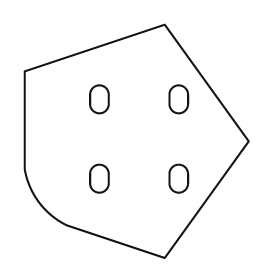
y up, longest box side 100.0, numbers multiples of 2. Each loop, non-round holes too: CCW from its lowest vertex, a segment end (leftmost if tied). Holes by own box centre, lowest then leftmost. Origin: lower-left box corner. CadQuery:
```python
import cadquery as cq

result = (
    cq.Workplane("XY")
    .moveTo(60.0, 0.0)
    .lineTo(96.0, 50.0)
    .lineTo(60.0, 100.0)
    .lineTo(0.0, 80.0)
    .lineTo(0.0, 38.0)
    .threePointArc((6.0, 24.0), (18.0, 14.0))
    .close()
    .moveTo(28.0, 32.0)
    .threePointArc((32.0, 28.0), (36.0, 32.0))
    .lineTo(36.0, 36.0)
    .threePointArc((32.0, 40.0), (28.0, 36.0))
    .close()
    .moveTo(62.0, 32.0)
    .threePointArc((66.0, 28.0), (70.0, 32.0))
    .lineTo(70.0, 36.0)
    .threePointArc((66.0, 40.0), (62.0, 36.0))
    .close()
    .moveTo(28.0, 66.0)
    .threePointArc((32.0, 62.0), (36.0, 66.0))
    .lineTo(36.0, 70.0)
    .threePointArc((32.0, 74.0), (28.0, 70.0))
    .close()
    .moveTo(62.0, 66.0)
    .threePointArc((66.0, 62.0), (70.0, 66.0))
    .lineTo(70.0, 70.0)
    .threePointArc((66.0, 74.0), (62.0, 70.0))
    .close()
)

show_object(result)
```